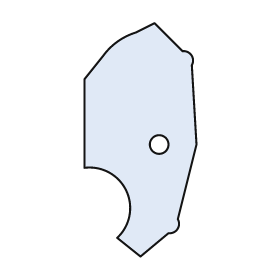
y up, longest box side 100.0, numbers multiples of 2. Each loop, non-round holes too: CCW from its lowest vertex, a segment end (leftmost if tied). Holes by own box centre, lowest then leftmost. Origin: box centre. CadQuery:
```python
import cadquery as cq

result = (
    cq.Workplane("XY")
    .moveTo(0.0, -50.0)
    .lineTo(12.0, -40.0)
    .threePointArc((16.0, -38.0), (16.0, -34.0))
    .lineTo(24.0, -2.0)
    .lineTo(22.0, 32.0)
    .threePointArc((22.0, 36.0), (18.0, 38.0))
    .lineTo(6.0, 50.0)
    .lineTo(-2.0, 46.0)
    .threePointArc((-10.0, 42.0), (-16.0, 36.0))
    .lineTo(-24.0, 26.0)
    .lineTo(-24.0, -12.0)
    .threePointArc((-6.0, -22.0), (-10.0, -42.0))
    .close()
    .moveTo(8.0, -2.0)
    .circle(4.0)
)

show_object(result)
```